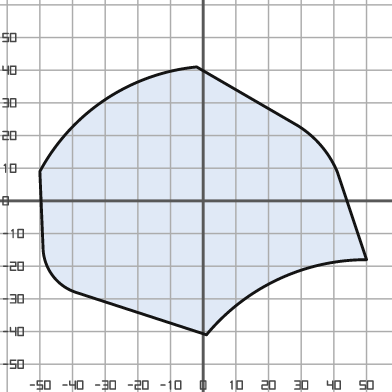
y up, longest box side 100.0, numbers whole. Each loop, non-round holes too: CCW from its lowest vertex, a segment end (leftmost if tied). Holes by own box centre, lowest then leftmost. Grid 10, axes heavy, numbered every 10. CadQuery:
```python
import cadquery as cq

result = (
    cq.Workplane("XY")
    .moveTo(1.0, -41.0)
    .threePointArc((23.0, -24.0), (50.0, -18.0))
    .lineTo(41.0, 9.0)
    .threePointArc((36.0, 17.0), (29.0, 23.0))
    .lineTo(-2.0, 41.0)
    .threePointArc((-30.0, 31.0), (-50.0, 9.0))
    .lineTo(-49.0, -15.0)
    .threePointArc((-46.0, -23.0), (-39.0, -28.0))
    .close()
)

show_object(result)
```